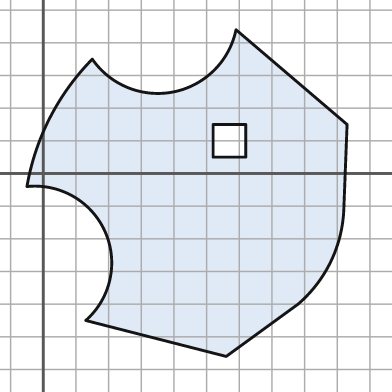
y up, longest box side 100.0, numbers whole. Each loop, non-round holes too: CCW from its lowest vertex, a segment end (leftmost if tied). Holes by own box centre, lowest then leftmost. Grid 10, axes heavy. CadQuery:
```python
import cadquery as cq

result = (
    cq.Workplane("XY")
    .moveTo(56.0, -56.0)
    .lineTo(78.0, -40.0)
    .threePointArc((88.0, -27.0), (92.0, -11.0))
    .lineTo(93.0, 15.0)
    .lineTo(59.0, 44.0)
    .threePointArc((40.0, 25.0), (15.0, 35.0))
    .threePointArc((2.0, 17.0), (-5.0, -4.0))
    .threePointArc((19.0, -18.0), (13.0, -45.0))
    .close()
    .moveTo(52.0, 5.0)
    .lineTo(62.0, 5.0)
    .lineTo(62.0, 15.0)
    .lineTo(52.0, 15.0)
    .close()
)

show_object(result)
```